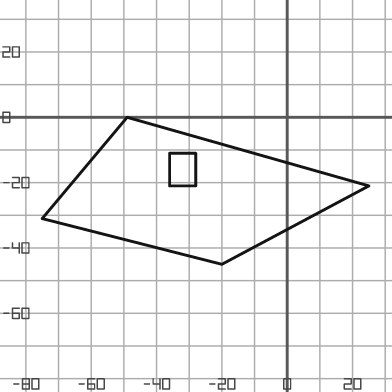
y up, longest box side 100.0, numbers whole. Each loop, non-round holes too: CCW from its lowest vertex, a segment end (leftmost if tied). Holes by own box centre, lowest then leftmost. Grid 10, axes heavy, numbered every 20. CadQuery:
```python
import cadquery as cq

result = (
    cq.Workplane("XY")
    .moveTo(-20.0, -45.0)
    .lineTo(25.0, -21.0)
    .lineTo(-49.0, 0.0)
    .lineTo(-75.0, -31.0)
    .close()
    .moveTo(-36.0, -21.0)
    .lineTo(-28.0, -21.0)
    .lineTo(-28.0, -11.0)
    .lineTo(-36.0, -11.0)
    .close()
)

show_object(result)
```